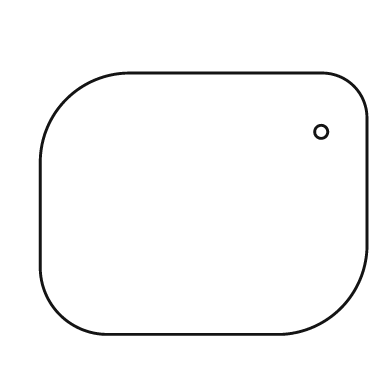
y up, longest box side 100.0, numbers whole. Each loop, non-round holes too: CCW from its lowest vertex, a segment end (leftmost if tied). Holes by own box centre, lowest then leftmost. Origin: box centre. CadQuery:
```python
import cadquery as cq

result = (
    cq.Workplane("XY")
    .moveTo(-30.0, -40.0)
    .lineTo(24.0, -40.0)
    .threePointArc((42.0, -32.0), (50.0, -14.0))
    .lineTo(50.0, 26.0)
    .threePointArc((46.0, 36.0), (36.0, 40.0))
    .lineTo(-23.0, 40.0)
    .threePointArc((-42.0, 32.0), (-50.0, 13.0))
    .lineTo(-50.0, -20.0)
    .threePointArc((-44.0, -34.0), (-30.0, -40.0))
    .close()
    .moveTo(36.0, 22.0)
    .circle(2.0)
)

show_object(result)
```